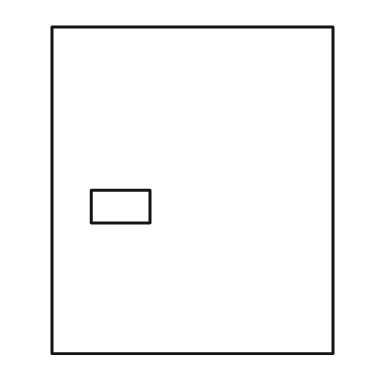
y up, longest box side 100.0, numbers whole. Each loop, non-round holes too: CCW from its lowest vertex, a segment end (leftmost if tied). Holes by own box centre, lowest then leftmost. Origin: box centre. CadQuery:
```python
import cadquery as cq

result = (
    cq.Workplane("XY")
    .moveTo(-43.0, -50.0)
    .lineTo(43.0, -50.0)
    .lineTo(43.0, 50.0)
    .lineTo(-43.0, 50.0)
    .close()
    .moveTo(-31.0, -10.0)
    .lineTo(-13.0, -10.0)
    .lineTo(-13.0, 0.0)
    .lineTo(-31.0, 0.0)
    .close()
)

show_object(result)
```